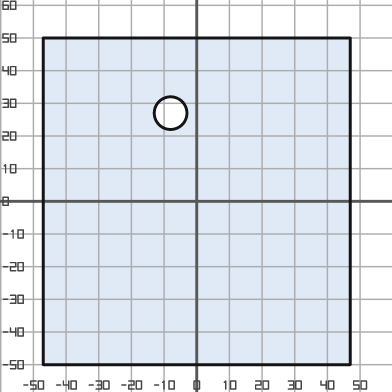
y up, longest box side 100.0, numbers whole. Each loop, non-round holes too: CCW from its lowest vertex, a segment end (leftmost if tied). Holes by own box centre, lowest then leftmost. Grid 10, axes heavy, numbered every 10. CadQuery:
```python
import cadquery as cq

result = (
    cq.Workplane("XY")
    .moveTo(-47.0, -50.0)
    .lineTo(47.0, -50.0)
    .lineTo(47.0, 50.0)
    .lineTo(-47.0, 50.0)
    .close()
    .moveTo(-8.0, 27.0)
    .circle(5.0)
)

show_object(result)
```